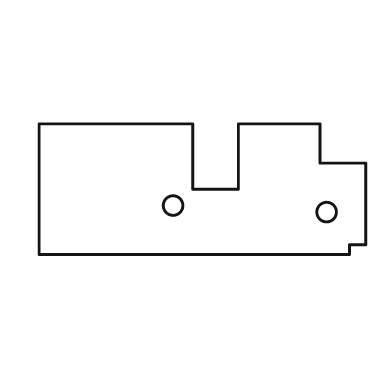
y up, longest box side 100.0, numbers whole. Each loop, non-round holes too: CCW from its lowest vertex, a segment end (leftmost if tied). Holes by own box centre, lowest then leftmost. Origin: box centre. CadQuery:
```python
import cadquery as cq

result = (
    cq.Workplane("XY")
    .moveTo(-50.0, -20.0)
    .lineTo(45.0, -20.0)
    .lineTo(45.0, -17.0)
    .lineTo(50.0, -17.0)
    .lineTo(50.0, 8.0)
    .lineTo(36.0, 8.0)
    .lineTo(36.0, 20.0)
    .lineTo(11.0, 20.0)
    .lineTo(11.0, 0.0)
    .lineTo(-3.0, 0.0)
    .lineTo(-3.0, 20.0)
    .lineTo(-50.0, 20.0)
    .close()
    .moveTo(38.0, -7.0)
    .circle(3.0)
    .moveTo(-9.0, -5.0)
    .circle(3.0)
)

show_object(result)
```